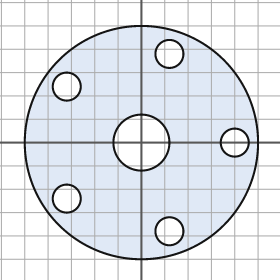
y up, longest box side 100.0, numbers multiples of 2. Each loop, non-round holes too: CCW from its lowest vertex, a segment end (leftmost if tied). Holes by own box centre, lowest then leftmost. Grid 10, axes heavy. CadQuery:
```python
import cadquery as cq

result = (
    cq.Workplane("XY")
    .moveTo(0.0, 0.0)
    .circle(50.0)
    .moveTo(12.0, -38.0)
    .circle(6.0)
    .moveTo(-32.0, -24.0)
    .circle(6.0)
    .moveTo(0.0, 0.0)
    .circle(12.0)
    .moveTo(40.0, 0.0)
    .circle(6.0)
    .moveTo(-32.0, 24.0)
    .circle(6.0)
    .moveTo(12.0, 38.0)
    .circle(6.0)
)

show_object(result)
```